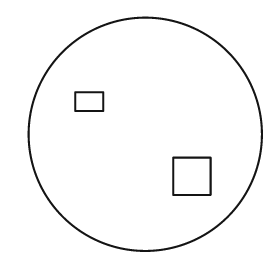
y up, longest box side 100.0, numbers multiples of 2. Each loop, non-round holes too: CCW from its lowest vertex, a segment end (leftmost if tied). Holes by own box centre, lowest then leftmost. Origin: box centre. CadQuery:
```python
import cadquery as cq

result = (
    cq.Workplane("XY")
    .moveTo(0.0, 0.0)
    .circle(50.0)
    .moveTo(12.0, -26.0)
    .lineTo(28.0, -26.0)
    .lineTo(28.0, -10.0)
    .lineTo(12.0, -10.0)
    .close()
    .moveTo(-30.0, 10.0)
    .lineTo(-18.0, 10.0)
    .lineTo(-18.0, 18.0)
    .lineTo(-30.0, 18.0)
    .close()
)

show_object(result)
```